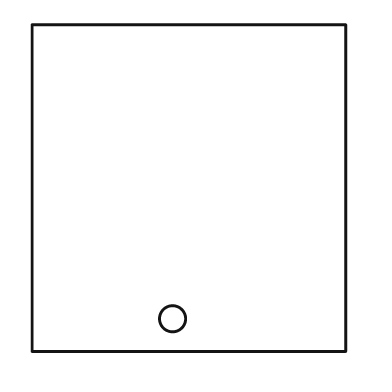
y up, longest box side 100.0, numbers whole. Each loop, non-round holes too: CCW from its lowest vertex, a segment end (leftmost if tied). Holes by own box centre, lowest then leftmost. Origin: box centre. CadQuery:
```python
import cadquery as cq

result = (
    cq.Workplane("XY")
    .moveTo(-48.0, -50.0)
    .lineTo(48.0, -50.0)
    .lineTo(48.0, 50.0)
    .lineTo(-48.0, 50.0)
    .close()
    .moveTo(-5.0, -40.0)
    .circle(4.0)
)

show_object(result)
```